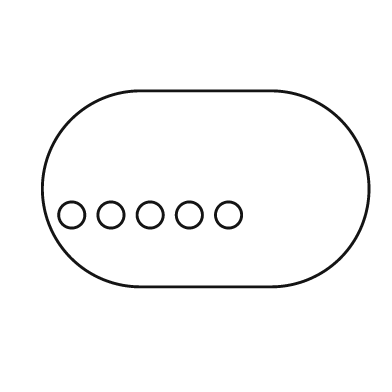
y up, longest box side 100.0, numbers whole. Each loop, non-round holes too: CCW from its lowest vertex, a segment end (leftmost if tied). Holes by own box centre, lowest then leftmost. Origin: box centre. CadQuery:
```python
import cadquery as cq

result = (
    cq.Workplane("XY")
    .moveTo(-20.0, -30.0)
    .lineTo(20.0, -30.0)
    .threePointArc((50.0, 0.0), (20.0, 30.0))
    .lineTo(-20.0, 30.0)
    .threePointArc((-50.0, 0.0), (-20.0, -30.0))
    .close()
    .moveTo(-41.0, -8.0)
    .circle(4.0)
    .moveTo(-29.0, -8.0)
    .circle(4.0)
    .moveTo(-17.0, -8.0)
    .circle(4.0)
    .moveTo(-5.0, -8.0)
    .circle(4.0)
    .moveTo(7.0, -8.0)
    .circle(4.0)
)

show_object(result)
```